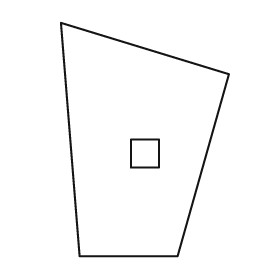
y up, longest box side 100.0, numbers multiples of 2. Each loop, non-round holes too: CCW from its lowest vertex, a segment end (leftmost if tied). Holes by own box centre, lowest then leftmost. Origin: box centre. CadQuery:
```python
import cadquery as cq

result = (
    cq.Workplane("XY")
    .moveTo(-28.0, -50.0)
    .lineTo(14.0, -50.0)
    .lineTo(36.0, 28.0)
    .lineTo(-36.0, 50.0)
    .close()
    .moveTo(-6.0, -12.0)
    .lineTo(6.0, -12.0)
    .lineTo(6.0, 0.0)
    .lineTo(-6.0, 0.0)
    .close()
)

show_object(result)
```